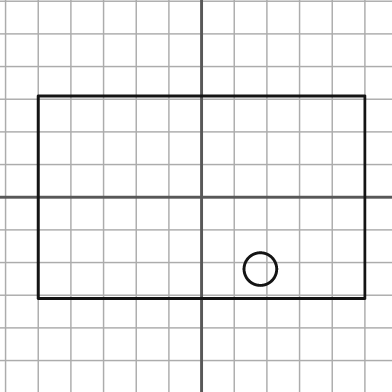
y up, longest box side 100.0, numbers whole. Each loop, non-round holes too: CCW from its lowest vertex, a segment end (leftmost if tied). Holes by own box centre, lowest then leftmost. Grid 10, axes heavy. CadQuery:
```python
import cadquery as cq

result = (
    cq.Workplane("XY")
    .moveTo(-50.0, -31.0)
    .lineTo(50.0, -31.0)
    .lineTo(50.0, 31.0)
    .lineTo(-50.0, 31.0)
    .close()
    .moveTo(18.0, -22.0)
    .circle(5.0)
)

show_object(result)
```